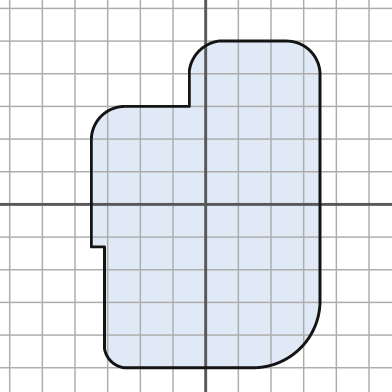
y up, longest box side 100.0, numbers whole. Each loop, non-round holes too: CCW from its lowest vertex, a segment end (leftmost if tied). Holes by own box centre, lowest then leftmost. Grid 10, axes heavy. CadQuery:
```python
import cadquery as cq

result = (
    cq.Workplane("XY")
    .moveTo(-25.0, -50.0)
    .lineTo(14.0, -50.0)
    .threePointArc((29.0, -44.0), (35.0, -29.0))
    .lineTo(35.0, 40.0)
    .threePointArc((32.0, 47.0), (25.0, 50.0))
    .lineTo(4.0, 50.0)
    .threePointArc((-2.0, 47.0), (-5.0, 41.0))
    .lineTo(-5.0, 30.0)
    .lineTo(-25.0, 30.0)
    .threePointArc((-32.0, 27.0), (-35.0, 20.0))
    .lineTo(-35.0, -13.0)
    .lineTo(-31.0, -13.0)
    .lineTo(-31.0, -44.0)
    .threePointArc((-29.0, -48.0), (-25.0, -50.0))
    .close()
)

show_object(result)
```